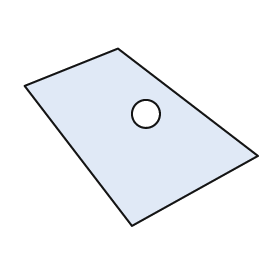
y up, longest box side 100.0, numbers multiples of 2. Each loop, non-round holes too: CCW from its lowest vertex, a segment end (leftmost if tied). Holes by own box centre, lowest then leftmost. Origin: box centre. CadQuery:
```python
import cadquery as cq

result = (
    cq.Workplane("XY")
    .moveTo(-4.0, -38.0)
    .lineTo(50.0, -8.0)
    .lineTo(-10.0, 38.0)
    .lineTo(-50.0, 22.0)
    .close()
    .moveTo(2.0, 10.0)
    .circle(6.0)
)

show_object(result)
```